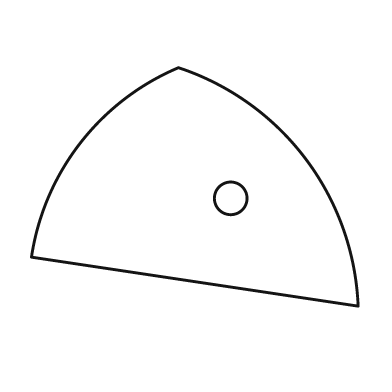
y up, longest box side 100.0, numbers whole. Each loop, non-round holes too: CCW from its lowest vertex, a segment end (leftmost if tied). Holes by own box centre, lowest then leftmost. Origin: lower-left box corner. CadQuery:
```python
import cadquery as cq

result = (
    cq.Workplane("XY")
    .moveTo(100.0, 0.0)
    .threePointArc((84.0, 45.0), (45.0, 73.0))
    .threePointArc((15.0, 50.0), (0.0, 15.0))
    .close()
    .moveTo(61.0, 33.0)
    .circle(5.0)
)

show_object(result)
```